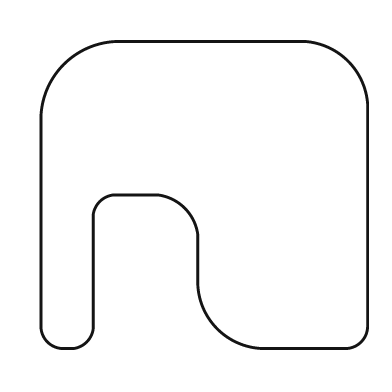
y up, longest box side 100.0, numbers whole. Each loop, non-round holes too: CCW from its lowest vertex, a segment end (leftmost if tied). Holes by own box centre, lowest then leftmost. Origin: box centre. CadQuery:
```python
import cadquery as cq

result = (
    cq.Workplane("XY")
    .moveTo(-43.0, -47.0)
    .lineTo(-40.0, -47.0)
    .threePointArc((-36.0, -45.0), (-34.0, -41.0))
    .lineTo(-34.0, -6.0)
    .threePointArc((-32.0, -2.0), (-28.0, 0.0))
    .lineTo(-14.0, 0.0)
    .threePointArc((-6.0, -4.0), (-2.0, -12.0))
    .lineTo(-2.0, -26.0)
    .threePointArc((4.0, -41.0), (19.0, -47.0))
    .lineTo(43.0, -47.0)
    .threePointArc((48.0, -45.0), (50.0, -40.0))
    .lineTo(50.0, 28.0)
    .threePointArc((44.0, 41.0), (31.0, 47.0))
    .lineTo(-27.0, 47.0)
    .threePointArc((-43.0, 40.0), (-50.0, 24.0))
    .lineTo(-50.0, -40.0)
    .threePointArc((-48.0, -45.0), (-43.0, -47.0))
    .close()
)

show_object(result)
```